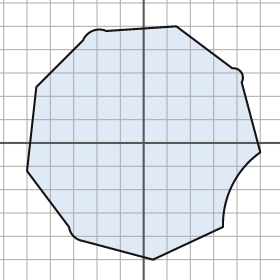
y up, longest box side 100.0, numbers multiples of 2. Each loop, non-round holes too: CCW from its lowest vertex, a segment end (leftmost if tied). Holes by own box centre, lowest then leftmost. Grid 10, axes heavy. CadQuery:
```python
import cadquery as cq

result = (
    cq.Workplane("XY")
    .moveTo(4.0, -50.0)
    .lineTo(34.0, -36.0)
    .threePointArc((38.0, -18.0), (50.0, -4.0))
    .lineTo(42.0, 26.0)
    .threePointArc((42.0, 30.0), (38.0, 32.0))
    .lineTo(14.0, 50.0)
    .lineTo(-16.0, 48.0)
    .threePointArc((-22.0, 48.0), (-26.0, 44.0))
    .lineTo(-46.0, 24.0)
    .lineTo(-50.0, -12.0)
    .lineTo(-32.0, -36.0)
    .threePointArc((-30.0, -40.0), (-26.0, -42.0))
    .close()
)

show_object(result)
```